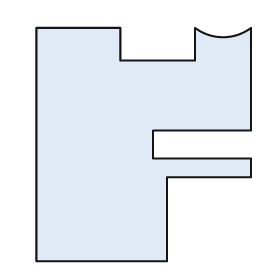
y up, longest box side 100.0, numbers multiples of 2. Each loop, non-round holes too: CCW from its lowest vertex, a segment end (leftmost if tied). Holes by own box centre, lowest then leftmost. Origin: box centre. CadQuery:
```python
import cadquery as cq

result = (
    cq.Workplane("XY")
    .moveTo(-46.0, -50.0)
    .lineTo(10.0, -50.0)
    .lineTo(10.0, -14.0)
    .lineTo(46.0, -14.0)
    .lineTo(46.0, -6.0)
    .lineTo(4.0, -6.0)
    .lineTo(4.0, 6.0)
    .lineTo(46.0, 6.0)
    .lineTo(46.0, 50.0)
    .threePointArc((34.0, 46.0), (22.0, 50.0))
    .lineTo(22.0, 36.0)
    .lineTo(-10.0, 36.0)
    .lineTo(-10.0, 50.0)
    .lineTo(-46.0, 50.0)
    .close()
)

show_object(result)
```